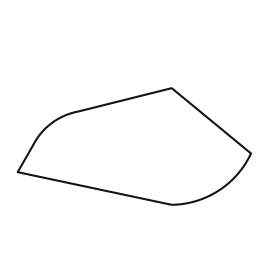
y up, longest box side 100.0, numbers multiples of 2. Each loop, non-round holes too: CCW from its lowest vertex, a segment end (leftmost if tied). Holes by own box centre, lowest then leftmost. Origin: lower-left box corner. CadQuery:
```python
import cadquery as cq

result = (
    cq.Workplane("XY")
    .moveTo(66.0, 0.0)
    .threePointArc((86.0, 6.0), (100.0, 22.0))
    .lineTo(66.0, 50.0)
    .lineTo(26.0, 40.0)
    .threePointArc((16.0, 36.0), (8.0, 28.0))
    .lineTo(0.0, 14.0)
    .close()
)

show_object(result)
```